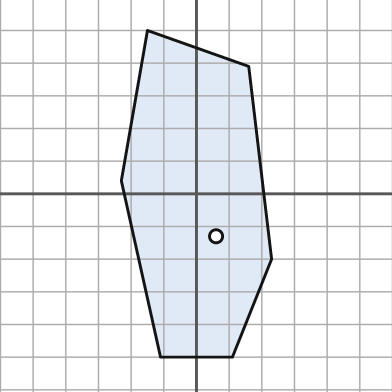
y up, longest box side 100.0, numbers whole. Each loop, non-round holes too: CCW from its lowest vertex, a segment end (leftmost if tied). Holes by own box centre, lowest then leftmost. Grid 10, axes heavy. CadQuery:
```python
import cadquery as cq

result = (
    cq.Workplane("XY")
    .moveTo(-11.0, -50.0)
    .lineTo(11.0, -50.0)
    .lineTo(23.0, -20.0)
    .lineTo(16.0, 39.0)
    .lineTo(-15.0, 50.0)
    .lineTo(-23.0, 4.0)
    .close()
    .moveTo(6.0, -13.0)
    .circle(2.0)
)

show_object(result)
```